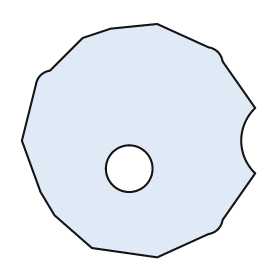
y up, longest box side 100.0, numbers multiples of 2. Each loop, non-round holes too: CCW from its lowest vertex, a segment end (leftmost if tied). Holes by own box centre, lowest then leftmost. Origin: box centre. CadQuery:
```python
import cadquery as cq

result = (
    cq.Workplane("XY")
    .moveTo(8.0, -50.0)
    .lineTo(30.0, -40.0)
    .threePointArc((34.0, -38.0), (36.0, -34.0))
    .lineTo(50.0, -14.0)
    .threePointArc((44.0, 0.0), (50.0, 14.0))
    .lineTo(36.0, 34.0)
    .threePointArc((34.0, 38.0), (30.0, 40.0))
    .lineTo(8.0, 50.0)
    .lineTo(-12.0, 48.0)
    .lineTo(-24.0, 44.0)
    .lineTo(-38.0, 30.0)
    .threePointArc((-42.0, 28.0), (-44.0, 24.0))
    .lineTo(-50.0, 0.0)
    .lineTo(-42.0, -22.0)
    .lineTo(-36.0, -32.0)
    .lineTo(-20.0, -46.0)
    .close()
    .moveTo(-4.0, -12.0)
    .circle(10.0)
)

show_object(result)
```